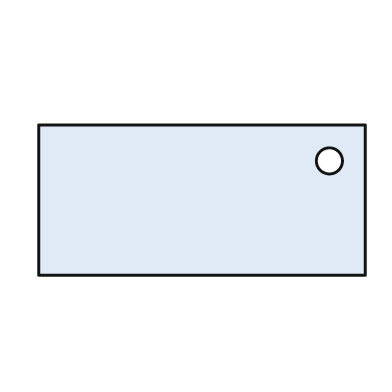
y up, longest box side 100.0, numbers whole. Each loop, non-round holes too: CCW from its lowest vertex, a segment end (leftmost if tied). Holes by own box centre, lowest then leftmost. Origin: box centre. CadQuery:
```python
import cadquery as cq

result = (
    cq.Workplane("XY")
    .moveTo(-50.0, -23.0)
    .lineTo(50.0, -23.0)
    .lineTo(50.0, 23.0)
    .lineTo(-50.0, 23.0)
    .close()
    .moveTo(39.0, 12.0)
    .circle(4.0)
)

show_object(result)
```